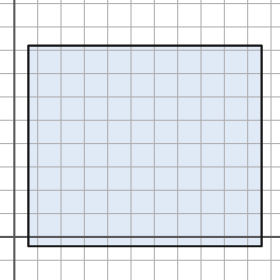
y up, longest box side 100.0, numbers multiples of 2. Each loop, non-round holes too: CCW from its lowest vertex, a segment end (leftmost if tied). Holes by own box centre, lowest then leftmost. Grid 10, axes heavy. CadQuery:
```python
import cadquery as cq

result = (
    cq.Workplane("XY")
    .moveTo(6.0, -4.0)
    .lineTo(106.0, -4.0)
    .lineTo(106.0, 82.0)
    .lineTo(6.0, 82.0)
    .close()
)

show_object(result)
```